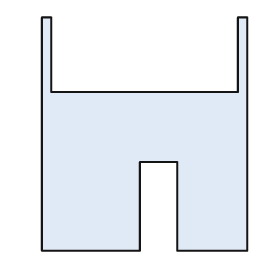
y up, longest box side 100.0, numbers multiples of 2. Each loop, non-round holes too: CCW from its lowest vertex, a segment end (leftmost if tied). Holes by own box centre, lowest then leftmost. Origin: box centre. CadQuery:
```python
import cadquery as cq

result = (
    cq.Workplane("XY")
    .moveTo(-44.0, -50.0)
    .lineTo(-2.0, -50.0)
    .lineTo(-2.0, -12.0)
    .lineTo(14.0, -12.0)
    .lineTo(14.0, -50.0)
    .lineTo(44.0, -50.0)
    .lineTo(44.0, 50.0)
    .lineTo(40.0, 50.0)
    .lineTo(40.0, 18.0)
    .lineTo(-40.0, 18.0)
    .lineTo(-40.0, 50.0)
    .lineTo(-44.0, 50.0)
    .close()
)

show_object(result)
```